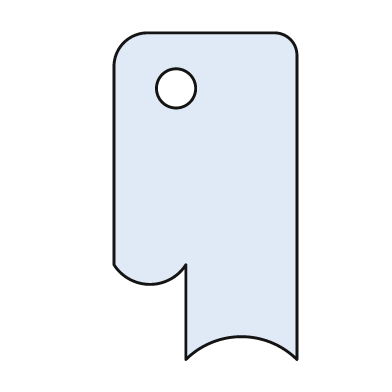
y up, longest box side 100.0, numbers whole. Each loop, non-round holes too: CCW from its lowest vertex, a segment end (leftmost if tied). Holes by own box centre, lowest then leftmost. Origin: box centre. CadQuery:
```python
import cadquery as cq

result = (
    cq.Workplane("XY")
    .moveTo(-6.0, -50.0)
    .threePointArc((11.0, -43.0), (28.0, -50.0))
    .lineTo(28.0, 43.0)
    .threePointArc((26.0, 48.0), (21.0, 50.0))
    .lineTo(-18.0, 50.0)
    .threePointArc((-25.0, 47.0), (-28.0, 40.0))
    .lineTo(-28.0, -21.0)
    .threePointArc((-17.0, -27.0), (-6.0, -21.0))
    .close()
    .moveTo(-9.0, 33.0)
    .circle(6.0)
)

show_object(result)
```